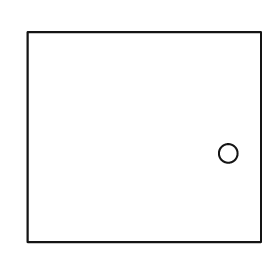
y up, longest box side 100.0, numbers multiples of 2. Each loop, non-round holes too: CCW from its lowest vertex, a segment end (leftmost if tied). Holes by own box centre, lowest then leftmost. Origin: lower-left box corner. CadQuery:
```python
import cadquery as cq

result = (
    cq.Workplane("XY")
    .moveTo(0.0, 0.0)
    .lineTo(100.0, 0.0)
    .lineTo(100.0, 90.0)
    .lineTo(0.0, 90.0)
    .close()
    .moveTo(86.0, 38.0)
    .circle(4.0)
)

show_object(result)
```